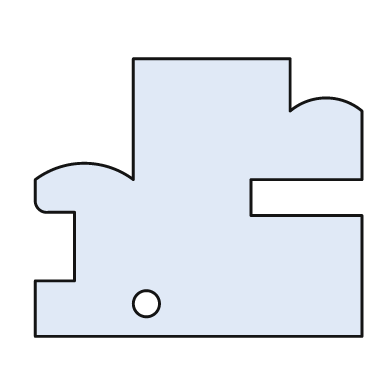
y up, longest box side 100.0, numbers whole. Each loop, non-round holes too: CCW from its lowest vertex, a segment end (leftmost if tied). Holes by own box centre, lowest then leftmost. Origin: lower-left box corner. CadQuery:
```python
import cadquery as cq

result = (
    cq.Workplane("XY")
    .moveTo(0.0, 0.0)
    .lineTo(100.0, 0.0)
    .lineTo(100.0, 37.0)
    .lineTo(66.0, 37.0)
    .lineTo(66.0, 48.0)
    .lineTo(100.0, 48.0)
    .lineTo(100.0, 69.0)
    .threePointArc((89.0, 73.0), (78.0, 69.0))
    .lineTo(78.0, 85.0)
    .lineTo(30.0, 85.0)
    .lineTo(30.0, 48.0)
    .threePointArc((15.0, 53.0), (0.0, 48.0))
    .lineTo(0.0, 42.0)
    .threePointArc((1.0, 39.0), (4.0, 38.0))
    .lineTo(12.0, 38.0)
    .lineTo(12.0, 17.0)
    .lineTo(0.0, 17.0)
    .close()
    .moveTo(34.0, 10.0)
    .circle(4.0)
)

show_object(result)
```